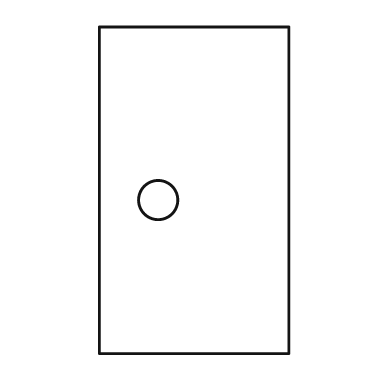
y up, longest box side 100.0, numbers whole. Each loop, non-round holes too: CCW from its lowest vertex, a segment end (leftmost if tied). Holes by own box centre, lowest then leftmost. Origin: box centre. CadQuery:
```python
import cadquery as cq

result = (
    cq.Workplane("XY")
    .moveTo(-29.0, -50.0)
    .lineTo(29.0, -50.0)
    .lineTo(29.0, 50.0)
    .lineTo(-29.0, 50.0)
    .close()
    .moveTo(-11.0, -3.0)
    .circle(6.0)
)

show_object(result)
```